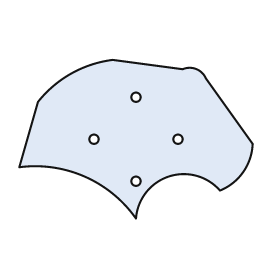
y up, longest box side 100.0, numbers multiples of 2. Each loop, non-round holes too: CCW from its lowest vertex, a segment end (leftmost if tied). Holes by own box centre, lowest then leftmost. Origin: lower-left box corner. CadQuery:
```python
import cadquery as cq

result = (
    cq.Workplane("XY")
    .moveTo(50.0, 0.0)
    .threePointArc((64.0, 18.0), (86.0, 12.0))
    .threePointArc((96.0, 20.0), (100.0, 32.0))
    .lineTo(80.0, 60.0)
    .threePointArc((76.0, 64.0), (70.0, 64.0))
    .lineTo(40.0, 68.0)
    .threePointArc((22.0, 62.0), (8.0, 50.0))
    .lineTo(0.0, 22.0)
    .threePointArc((28.0, 18.0), (50.0, 0.0))
    .close()
    .moveTo(50.0, 16.0)
    .circle(2.0)
    .moveTo(32.0, 34.0)
    .circle(2.0)
    .moveTo(68.0, 34.0)
    .circle(2.0)
    .moveTo(50.0, 52.0)
    .circle(2.0)
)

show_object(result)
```